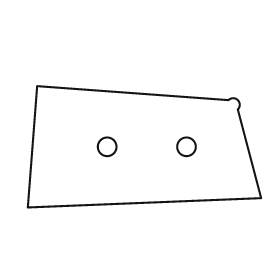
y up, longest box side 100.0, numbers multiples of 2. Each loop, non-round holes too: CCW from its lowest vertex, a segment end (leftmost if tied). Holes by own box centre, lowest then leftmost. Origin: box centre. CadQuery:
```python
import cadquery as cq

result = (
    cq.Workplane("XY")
    .moveTo(-50.0, -26.0)
    .lineTo(50.0, -22.0)
    .lineTo(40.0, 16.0)
    .threePointArc((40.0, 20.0), (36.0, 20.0))
    .lineTo(-46.0, 26.0)
    .close()
    .moveTo(-16.0, 0.0)
    .circle(4.0)
    .moveTo(18.0, 0.0)
    .circle(4.0)
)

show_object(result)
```